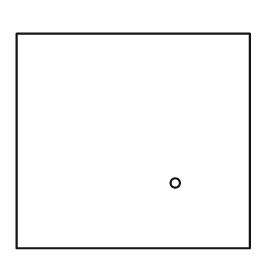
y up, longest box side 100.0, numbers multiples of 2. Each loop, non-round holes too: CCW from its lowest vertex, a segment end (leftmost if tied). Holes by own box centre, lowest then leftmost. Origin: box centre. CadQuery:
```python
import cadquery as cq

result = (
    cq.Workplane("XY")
    .moveTo(-50.0, -46.0)
    .lineTo(50.0, -46.0)
    .lineTo(50.0, 46.0)
    .lineTo(-50.0, 46.0)
    .close()
    .moveTo(18.0, -18.0)
    .circle(2.0)
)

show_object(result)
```